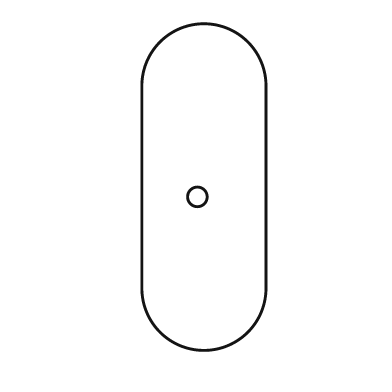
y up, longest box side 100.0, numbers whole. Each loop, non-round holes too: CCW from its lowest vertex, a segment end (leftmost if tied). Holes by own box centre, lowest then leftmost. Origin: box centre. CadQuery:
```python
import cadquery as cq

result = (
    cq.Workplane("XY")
    .moveTo(-19.0, -31.0)
    .threePointArc((0.0, -50.0), (19.0, -31.0))
    .lineTo(19.0, 31.0)
    .threePointArc((0.0, 50.0), (-19.0, 31.0))
    .close()
    .moveTo(-2.0, -3.0)
    .circle(3.0)
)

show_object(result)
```